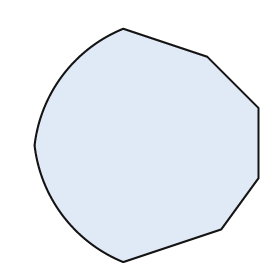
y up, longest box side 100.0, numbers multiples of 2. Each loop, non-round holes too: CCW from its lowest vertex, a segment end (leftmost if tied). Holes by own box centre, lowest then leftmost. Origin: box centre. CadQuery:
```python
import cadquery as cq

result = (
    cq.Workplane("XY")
    .moveTo(-10.0, -50.0)
    .lineTo(32.0, -36.0)
    .lineTo(48.0, -14.0)
    .lineTo(48.0, 16.0)
    .lineTo(26.0, 38.0)
    .lineTo(-10.0, 50.0)
    .threePointArc((-36.0, 30.0), (-48.0, 0.0))
    .threePointArc((-36.0, -30.0), (-10.0, -50.0))
    .close()
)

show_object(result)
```